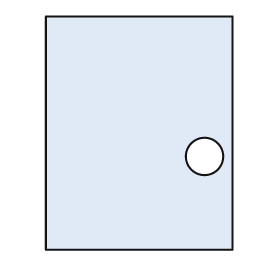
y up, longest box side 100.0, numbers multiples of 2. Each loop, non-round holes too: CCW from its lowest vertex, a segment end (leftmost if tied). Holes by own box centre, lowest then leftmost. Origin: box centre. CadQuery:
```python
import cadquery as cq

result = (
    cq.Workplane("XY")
    .moveTo(-40.0, -50.0)
    .lineTo(40.0, -50.0)
    .lineTo(40.0, 50.0)
    .lineTo(-40.0, 50.0)
    .close()
    .moveTo(28.0, -10.0)
    .circle(8.0)
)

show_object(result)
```